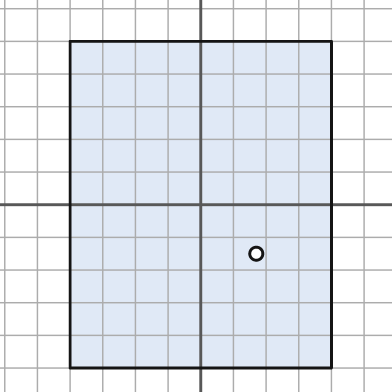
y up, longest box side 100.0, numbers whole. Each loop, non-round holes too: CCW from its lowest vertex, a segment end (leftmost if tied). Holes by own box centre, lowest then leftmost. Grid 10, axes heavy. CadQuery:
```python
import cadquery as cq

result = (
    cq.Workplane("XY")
    .moveTo(-40.0, -50.0)
    .lineTo(40.0, -50.0)
    .lineTo(40.0, 50.0)
    .lineTo(-40.0, 50.0)
    .close()
    .moveTo(17.0, -15.0)
    .circle(2.0)
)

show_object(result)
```